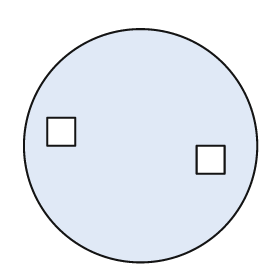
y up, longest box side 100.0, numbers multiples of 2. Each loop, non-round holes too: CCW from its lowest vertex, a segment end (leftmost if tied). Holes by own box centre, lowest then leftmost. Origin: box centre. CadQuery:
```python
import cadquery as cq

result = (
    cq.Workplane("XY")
    .moveTo(0.0, 0.0)
    .circle(50.0)
    .moveTo(24.0, -12.0)
    .lineTo(36.0, -12.0)
    .lineTo(36.0, 0.0)
    .lineTo(24.0, 0.0)
    .close()
    .moveTo(-40.0, 0.0)
    .lineTo(-28.0, 0.0)
    .lineTo(-28.0, 12.0)
    .lineTo(-40.0, 12.0)
    .close()
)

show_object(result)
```